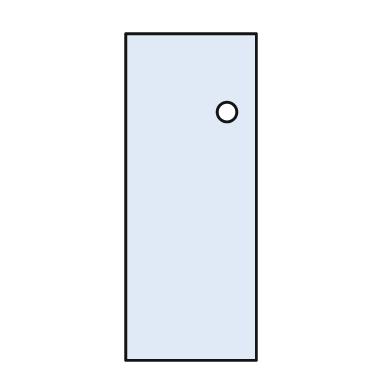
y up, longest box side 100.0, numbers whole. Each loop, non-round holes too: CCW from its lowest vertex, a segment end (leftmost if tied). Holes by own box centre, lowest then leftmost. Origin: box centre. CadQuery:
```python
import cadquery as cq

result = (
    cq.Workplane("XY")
    .moveTo(-20.0, -50.0)
    .lineTo(20.0, -50.0)
    .lineTo(20.0, 50.0)
    .lineTo(-20.0, 50.0)
    .close()
    .moveTo(11.0, 26.0)
    .circle(3.0)
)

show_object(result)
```